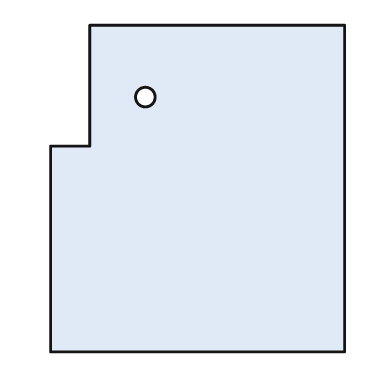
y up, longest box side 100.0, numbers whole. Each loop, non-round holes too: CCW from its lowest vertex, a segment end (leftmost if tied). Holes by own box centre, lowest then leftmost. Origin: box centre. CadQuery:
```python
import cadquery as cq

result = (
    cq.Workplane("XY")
    .moveTo(-45.0, -50.0)
    .lineTo(45.0, -50.0)
    .lineTo(45.0, 50.0)
    .lineTo(-33.0, 50.0)
    .lineTo(-33.0, 13.0)
    .lineTo(-45.0, 13.0)
    .close()
    .moveTo(-16.0, 28.0)
    .circle(3.0)
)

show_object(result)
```